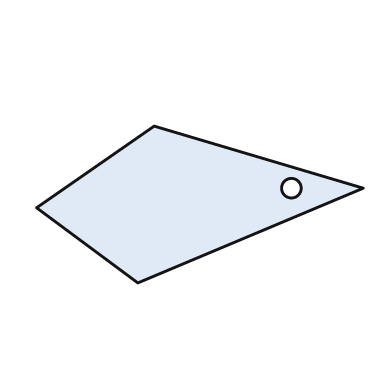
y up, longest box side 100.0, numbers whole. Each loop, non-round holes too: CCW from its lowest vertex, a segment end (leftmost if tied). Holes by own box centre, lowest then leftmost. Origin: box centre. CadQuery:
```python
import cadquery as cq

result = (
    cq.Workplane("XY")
    .moveTo(-19.0, -24.0)
    .lineTo(50.0, 5.0)
    .lineTo(-14.0, 24.0)
    .lineTo(-50.0, -1.0)
    .close()
    .moveTo(28.0, 5.0)
    .circle(3.0)
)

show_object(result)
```